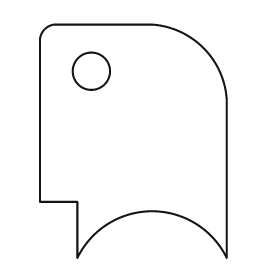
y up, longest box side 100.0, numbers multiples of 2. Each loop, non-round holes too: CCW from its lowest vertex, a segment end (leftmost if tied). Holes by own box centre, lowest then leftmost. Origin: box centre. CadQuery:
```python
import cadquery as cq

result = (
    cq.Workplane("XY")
    .moveTo(-24.0, -50.0)
    .threePointArc((8.0, -30.0), (40.0, -50.0))
    .lineTo(40.0, 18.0)
    .threePointArc((30.0, 40.0), (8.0, 50.0))
    .lineTo(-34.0, 50.0)
    .threePointArc((-38.0, 48.0), (-40.0, 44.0))
    .lineTo(-40.0, -26.0)
    .lineTo(-24.0, -26.0)
    .close()
    .moveTo(-18.0, 30.0)
    .circle(8.0)
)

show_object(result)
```